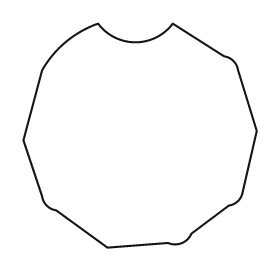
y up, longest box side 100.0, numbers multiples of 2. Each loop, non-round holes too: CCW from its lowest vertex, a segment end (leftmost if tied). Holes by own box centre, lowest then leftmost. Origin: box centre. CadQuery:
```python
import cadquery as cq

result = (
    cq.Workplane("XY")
    .moveTo(-14.0, -48.0)
    .lineTo(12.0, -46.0)
    .threePointArc((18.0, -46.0), (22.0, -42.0))
    .lineTo(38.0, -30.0)
    .threePointArc((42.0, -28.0), (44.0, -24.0))
    .lineTo(50.0, 2.0)
    .lineTo(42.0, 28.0)
    .threePointArc((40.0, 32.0), (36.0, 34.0))
    .lineTo(14.0, 48.0)
    .threePointArc((-2.0, 40.0), (-18.0, 48.0))
    .threePointArc((-32.0, 40.0), (-42.0, 28.0))
    .lineTo(-50.0, -2.0)
    .lineTo(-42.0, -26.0)
    .threePointArc((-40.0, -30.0), (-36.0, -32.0))
    .close()
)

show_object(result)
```